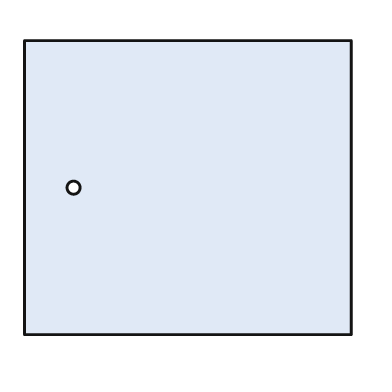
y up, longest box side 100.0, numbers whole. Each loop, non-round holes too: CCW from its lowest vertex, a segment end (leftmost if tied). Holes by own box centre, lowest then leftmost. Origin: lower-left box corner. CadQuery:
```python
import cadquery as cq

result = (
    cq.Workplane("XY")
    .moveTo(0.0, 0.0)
    .lineTo(100.0, 0.0)
    .lineTo(100.0, 90.0)
    .lineTo(0.0, 90.0)
    .close()
    .moveTo(15.0, 45.0)
    .circle(2.0)
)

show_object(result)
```